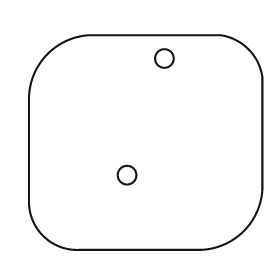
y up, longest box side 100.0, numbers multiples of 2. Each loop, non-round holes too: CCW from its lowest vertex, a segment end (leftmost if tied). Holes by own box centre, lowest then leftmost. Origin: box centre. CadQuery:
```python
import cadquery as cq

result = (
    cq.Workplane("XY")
    .moveTo(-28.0, -46.0)
    .lineTo(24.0, -46.0)
    .threePointArc((42.0, -38.0), (50.0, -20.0))
    .lineTo(50.0, 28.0)
    .threePointArc((44.0, 40.0), (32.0, 46.0))
    .lineTo(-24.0, 46.0)
    .threePointArc((-42.0, 38.0), (-50.0, 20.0))
    .lineTo(-50.0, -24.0)
    .threePointArc((-44.0, -40.0), (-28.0, -46.0))
    .close()
    .moveTo(-8.0, -14.0)
    .circle(4.0)
    .moveTo(8.0, 36.0)
    .circle(4.0)
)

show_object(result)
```